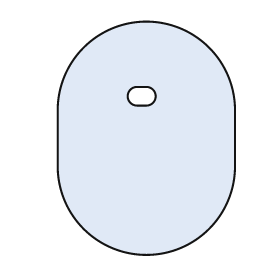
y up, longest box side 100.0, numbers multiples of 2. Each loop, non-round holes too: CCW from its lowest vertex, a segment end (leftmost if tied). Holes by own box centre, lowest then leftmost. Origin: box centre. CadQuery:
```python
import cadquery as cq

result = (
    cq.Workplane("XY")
    .moveTo(-38.0, -12.0)
    .threePointArc((0.0, -50.0), (38.0, -12.0))
    .lineTo(38.0, 12.0)
    .threePointArc((0.0, 50.0), (-38.0, 12.0))
    .close()
    .moveTo(-4.0, 14.0)
    .lineTo(0.0, 14.0)
    .threePointArc((4.0, 18.0), (0.0, 22.0))
    .lineTo(-4.0, 22.0)
    .threePointArc((-8.0, 18.0), (-4.0, 14.0))
    .close()
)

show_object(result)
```